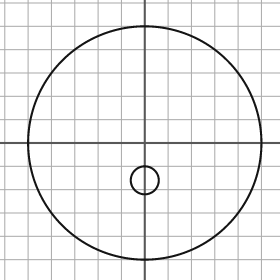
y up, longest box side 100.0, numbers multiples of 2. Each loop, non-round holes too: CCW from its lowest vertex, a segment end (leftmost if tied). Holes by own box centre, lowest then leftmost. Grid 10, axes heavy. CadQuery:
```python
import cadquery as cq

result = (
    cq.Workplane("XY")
    .moveTo(0.0, 0.0)
    .circle(50.0)
    .moveTo(0.0, -16.0)
    .circle(6.0)
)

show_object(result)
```